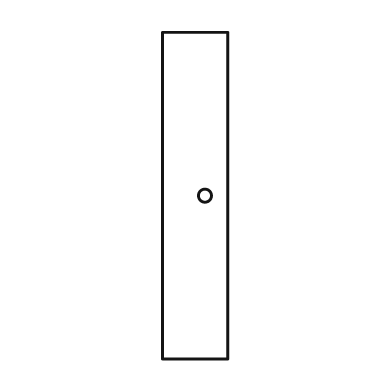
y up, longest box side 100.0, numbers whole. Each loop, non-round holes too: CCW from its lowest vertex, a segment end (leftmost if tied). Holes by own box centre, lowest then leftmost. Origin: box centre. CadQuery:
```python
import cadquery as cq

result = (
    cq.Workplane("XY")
    .moveTo(-10.0, -50.0)
    .lineTo(10.0, -50.0)
    .lineTo(10.0, 50.0)
    .lineTo(-10.0, 50.0)
    .close()
    .moveTo(3.0, 0.0)
    .circle(2.0)
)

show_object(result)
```